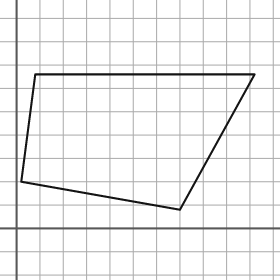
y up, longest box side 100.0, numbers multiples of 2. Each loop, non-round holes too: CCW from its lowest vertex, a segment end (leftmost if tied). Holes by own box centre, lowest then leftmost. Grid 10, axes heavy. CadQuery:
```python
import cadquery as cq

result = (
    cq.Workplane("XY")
    .moveTo(70.0, 8.0)
    .lineTo(102.0, 66.0)
    .lineTo(8.0, 66.0)
    .lineTo(2.0, 20.0)
    .close()
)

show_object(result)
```